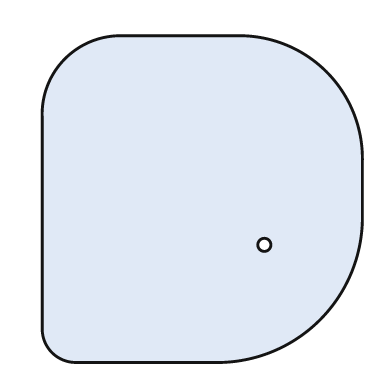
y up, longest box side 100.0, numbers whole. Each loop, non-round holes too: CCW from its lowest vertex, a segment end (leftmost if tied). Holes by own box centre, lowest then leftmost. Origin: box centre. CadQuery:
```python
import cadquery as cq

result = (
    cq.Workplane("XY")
    .moveTo(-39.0, -50.0)
    .lineTo(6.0, -50.0)
    .threePointArc((36.0, -37.0), (49.0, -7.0))
    .lineTo(49.0, 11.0)
    .threePointArc((38.0, 39.0), (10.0, 50.0))
    .lineTo(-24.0, 50.0)
    .threePointArc((-42.0, 43.0), (-49.0, 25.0))
    .lineTo(-49.0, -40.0)
    .threePointArc((-46.0, -47.0), (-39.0, -50.0))
    .close()
    .moveTo(19.0, -14.0)
    .circle(2.0)
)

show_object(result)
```